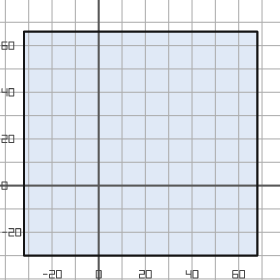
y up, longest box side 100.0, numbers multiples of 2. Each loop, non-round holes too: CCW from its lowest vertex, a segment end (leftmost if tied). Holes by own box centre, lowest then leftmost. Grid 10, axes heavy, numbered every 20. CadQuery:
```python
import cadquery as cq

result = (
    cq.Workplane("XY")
    .moveTo(-32.0, -30.0)
    .lineTo(68.0, -30.0)
    .lineTo(68.0, 66.0)
    .lineTo(-32.0, 66.0)
    .close()
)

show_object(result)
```